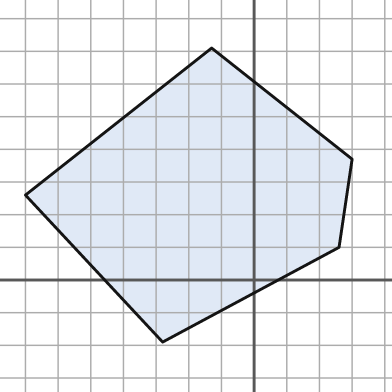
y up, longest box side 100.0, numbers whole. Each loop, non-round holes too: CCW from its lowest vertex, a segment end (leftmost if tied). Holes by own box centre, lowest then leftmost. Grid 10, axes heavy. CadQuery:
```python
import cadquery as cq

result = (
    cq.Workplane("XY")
    .moveTo(-28.0, -19.0)
    .lineTo(26.0, 10.0)
    .lineTo(30.0, 37.0)
    .lineTo(-13.0, 71.0)
    .lineTo(-70.0, 26.0)
    .close()
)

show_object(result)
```